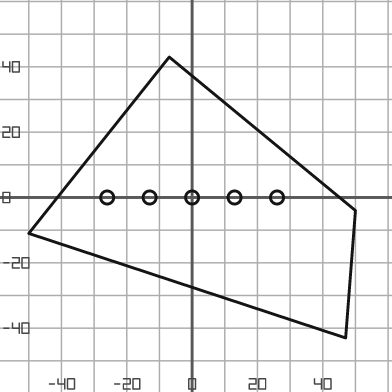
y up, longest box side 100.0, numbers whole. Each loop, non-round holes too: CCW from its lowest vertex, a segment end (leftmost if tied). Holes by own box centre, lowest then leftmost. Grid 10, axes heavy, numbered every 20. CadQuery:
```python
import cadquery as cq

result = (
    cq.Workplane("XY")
    .moveTo(47.0, -43.0)
    .lineTo(50.0, -4.0)
    .lineTo(-7.0, 43.0)
    .lineTo(-50.0, -11.0)
    .close()
    .moveTo(-26.0, 0.0)
    .circle(2.0)
    .moveTo(-13.0, 0.0)
    .circle(2.0)
    .moveTo(0.0, 0.0)
    .circle(2.0)
    .moveTo(13.0, 0.0)
    .circle(2.0)
    .moveTo(26.0, 0.0)
    .circle(2.0)
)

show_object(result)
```